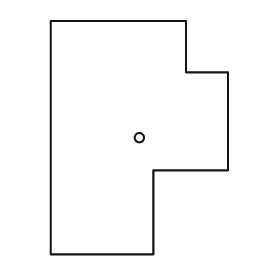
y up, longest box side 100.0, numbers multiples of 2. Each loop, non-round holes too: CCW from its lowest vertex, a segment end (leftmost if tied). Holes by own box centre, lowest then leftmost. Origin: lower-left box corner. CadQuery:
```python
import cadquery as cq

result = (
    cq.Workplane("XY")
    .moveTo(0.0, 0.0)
    .lineTo(44.0, 0.0)
    .lineTo(44.0, 36.0)
    .lineTo(76.0, 36.0)
    .lineTo(76.0, 78.0)
    .lineTo(58.0, 78.0)
    .lineTo(58.0, 100.0)
    .lineTo(0.0, 100.0)
    .close()
    .moveTo(38.0, 50.0)
    .circle(2.0)
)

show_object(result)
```